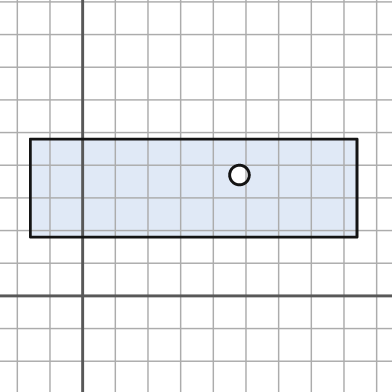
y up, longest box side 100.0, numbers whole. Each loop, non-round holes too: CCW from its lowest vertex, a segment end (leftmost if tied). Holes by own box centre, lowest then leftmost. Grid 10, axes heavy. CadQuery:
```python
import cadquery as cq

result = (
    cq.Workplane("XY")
    .moveTo(-16.0, 18.0)
    .lineTo(84.0, 18.0)
    .lineTo(84.0, 48.0)
    .lineTo(-16.0, 48.0)
    .close()
    .moveTo(48.0, 37.0)
    .circle(3.0)
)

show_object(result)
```